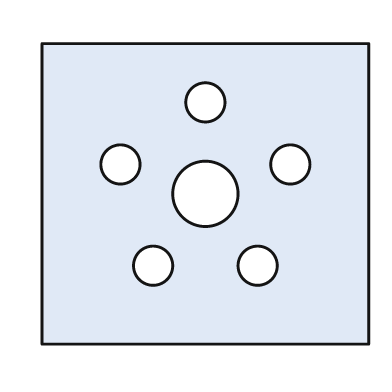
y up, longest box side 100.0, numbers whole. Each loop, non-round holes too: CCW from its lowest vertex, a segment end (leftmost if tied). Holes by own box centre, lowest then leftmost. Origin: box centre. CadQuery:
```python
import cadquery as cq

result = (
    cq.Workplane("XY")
    .moveTo(-50.0, -46.0)
    .lineTo(50.0, -46.0)
    .lineTo(50.0, 46.0)
    .lineTo(-50.0, 46.0)
    .close()
    .moveTo(-16.0, -22.0)
    .circle(6.0)
    .moveTo(16.0, -22.0)
    .circle(6.0)
    .moveTo(0.0, 0.0)
    .circle(10.0)
    .moveTo(-26.0, 9.0)
    .circle(6.0)
    .moveTo(26.0, 9.0)
    .circle(6.0)
    .moveTo(0.0, 28.0)
    .circle(6.0)
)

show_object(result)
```